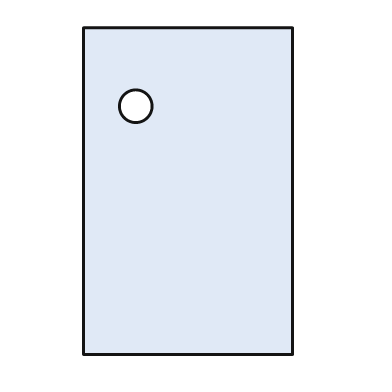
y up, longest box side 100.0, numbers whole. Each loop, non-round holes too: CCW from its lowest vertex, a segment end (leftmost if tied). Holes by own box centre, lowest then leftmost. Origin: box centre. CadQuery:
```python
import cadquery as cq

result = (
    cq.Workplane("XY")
    .moveTo(-32.0, -50.0)
    .lineTo(32.0, -50.0)
    .lineTo(32.0, 50.0)
    .lineTo(-32.0, 50.0)
    .close()
    .moveTo(-16.0, 26.0)
    .circle(5.0)
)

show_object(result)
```